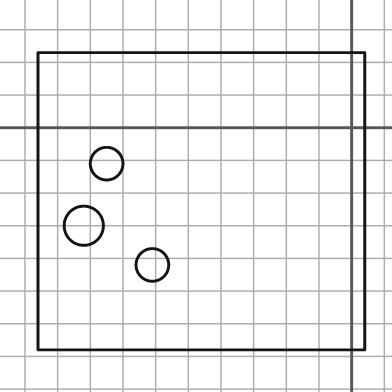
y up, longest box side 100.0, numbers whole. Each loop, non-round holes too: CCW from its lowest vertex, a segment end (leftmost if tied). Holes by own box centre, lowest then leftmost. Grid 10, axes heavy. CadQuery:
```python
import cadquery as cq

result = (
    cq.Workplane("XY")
    .moveTo(-96.0, -68.0)
    .lineTo(4.0, -68.0)
    .lineTo(4.0, 23.0)
    .lineTo(-96.0, 23.0)
    .close()
    .moveTo(-61.0, -42.0)
    .circle(5.0)
    .moveTo(-82.0, -30.0)
    .circle(6.0)
    .moveTo(-75.0, -11.0)
    .circle(5.0)
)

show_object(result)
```